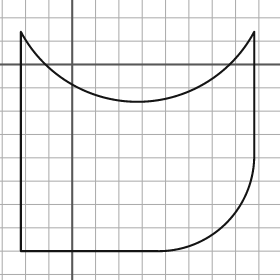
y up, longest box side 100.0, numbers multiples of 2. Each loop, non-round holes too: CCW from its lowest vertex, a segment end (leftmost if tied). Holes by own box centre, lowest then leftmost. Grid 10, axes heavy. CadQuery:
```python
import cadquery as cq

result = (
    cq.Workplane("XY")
    .moveTo(-22.0, -80.0)
    .lineTo(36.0, -80.0)
    .threePointArc((66.0, -68.0), (78.0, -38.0))
    .lineTo(78.0, 14.0)
    .threePointArc((28.0, -16.0), (-22.0, 14.0))
    .close()
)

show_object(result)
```